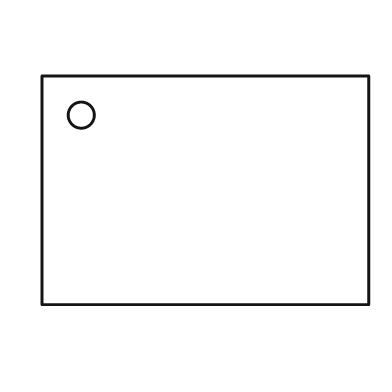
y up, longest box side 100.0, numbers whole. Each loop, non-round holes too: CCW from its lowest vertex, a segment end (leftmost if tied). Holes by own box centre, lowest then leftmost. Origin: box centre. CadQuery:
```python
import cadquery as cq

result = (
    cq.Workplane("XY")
    .moveTo(-50.0, -35.0)
    .lineTo(50.0, -35.0)
    .lineTo(50.0, 35.0)
    .lineTo(-50.0, 35.0)
    .close()
    .moveTo(-38.0, 23.0)
    .circle(4.0)
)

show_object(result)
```